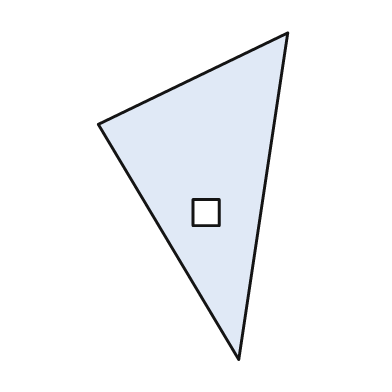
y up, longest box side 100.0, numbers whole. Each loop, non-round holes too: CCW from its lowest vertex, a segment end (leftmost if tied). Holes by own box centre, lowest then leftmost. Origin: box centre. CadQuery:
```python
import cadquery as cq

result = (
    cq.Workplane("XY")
    .moveTo(14.0, -50.0)
    .lineTo(29.0, 50.0)
    .lineTo(-29.0, 22.0)
    .close()
    .moveTo(0.0, -9.0)
    .lineTo(8.0, -9.0)
    .lineTo(8.0, -1.0)
    .lineTo(0.0, -1.0)
    .close()
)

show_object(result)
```